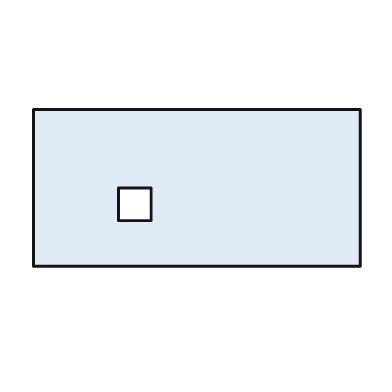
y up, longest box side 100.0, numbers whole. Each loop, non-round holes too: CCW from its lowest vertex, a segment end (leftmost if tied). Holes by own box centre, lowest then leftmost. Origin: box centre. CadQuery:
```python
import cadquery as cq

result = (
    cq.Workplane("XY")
    .moveTo(-50.0, -24.0)
    .lineTo(50.0, -24.0)
    .lineTo(50.0, 24.0)
    .lineTo(-50.0, 24.0)
    .close()
    .moveTo(-24.0, -10.0)
    .lineTo(-14.0, -10.0)
    .lineTo(-14.0, 0.0)
    .lineTo(-24.0, 0.0)
    .close()
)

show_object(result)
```